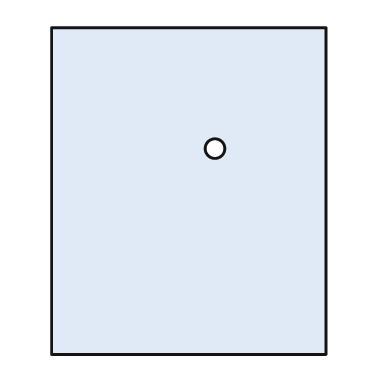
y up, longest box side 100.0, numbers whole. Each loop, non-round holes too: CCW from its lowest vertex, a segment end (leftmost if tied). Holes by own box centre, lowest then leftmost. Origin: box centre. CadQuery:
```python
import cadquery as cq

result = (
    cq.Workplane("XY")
    .moveTo(-42.0, -50.0)
    .lineTo(42.0, -50.0)
    .lineTo(42.0, 50.0)
    .lineTo(-42.0, 50.0)
    .close()
    .moveTo(8.0, 13.0)
    .circle(3.0)
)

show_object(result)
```